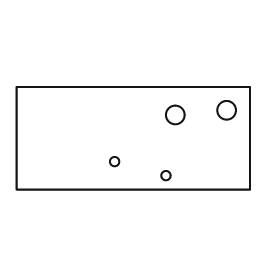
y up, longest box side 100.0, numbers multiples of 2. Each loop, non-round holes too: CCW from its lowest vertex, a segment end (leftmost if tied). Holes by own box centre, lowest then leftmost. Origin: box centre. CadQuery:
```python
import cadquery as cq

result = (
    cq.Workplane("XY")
    .moveTo(-50.0, -22.0)
    .lineTo(50.0, -22.0)
    .lineTo(50.0, 22.0)
    .lineTo(-50.0, 22.0)
    .close()
    .moveTo(14.0, -16.0)
    .circle(2.0)
    .moveTo(-8.0, -10.0)
    .circle(2.0)
    .moveTo(18.0, 10.0)
    .circle(4.0)
    .moveTo(40.0, 12.0)
    .circle(4.0)
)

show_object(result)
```